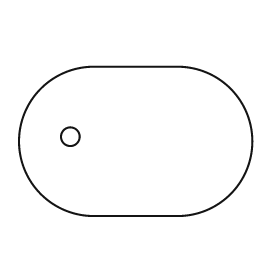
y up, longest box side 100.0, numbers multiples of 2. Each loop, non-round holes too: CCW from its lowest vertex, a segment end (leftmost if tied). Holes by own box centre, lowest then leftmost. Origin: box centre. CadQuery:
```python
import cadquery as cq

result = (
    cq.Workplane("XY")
    .moveTo(-18.0, -32.0)
    .lineTo(18.0, -32.0)
    .threePointArc((50.0, 0.0), (18.0, 32.0))
    .lineTo(-18.0, 32.0)
    .threePointArc((-50.0, 0.0), (-18.0, -32.0))
    .close()
    .moveTo(-28.0, 2.0)
    .circle(4.0)
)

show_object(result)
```